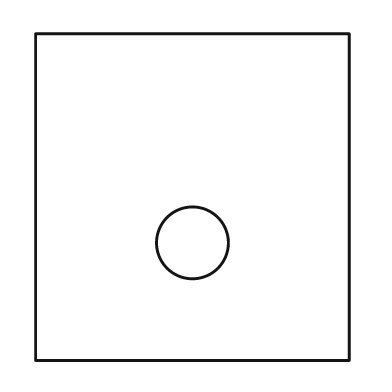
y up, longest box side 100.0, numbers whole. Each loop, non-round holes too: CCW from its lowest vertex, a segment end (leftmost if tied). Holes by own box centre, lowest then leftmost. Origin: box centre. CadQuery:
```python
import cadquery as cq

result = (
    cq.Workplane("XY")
    .moveTo(-48.0, -50.0)
    .lineTo(48.0, -50.0)
    .lineTo(48.0, 50.0)
    .lineTo(-48.0, 50.0)
    .close()
    .moveTo(0.0, -14.0)
    .circle(11.0)
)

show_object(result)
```